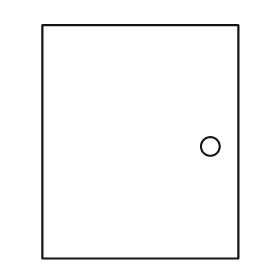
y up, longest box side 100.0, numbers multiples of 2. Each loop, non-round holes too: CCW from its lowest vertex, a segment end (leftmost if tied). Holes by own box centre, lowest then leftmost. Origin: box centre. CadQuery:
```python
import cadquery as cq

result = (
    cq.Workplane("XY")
    .moveTo(-42.0, -50.0)
    .lineTo(42.0, -50.0)
    .lineTo(42.0, 50.0)
    .lineTo(-42.0, 50.0)
    .close()
    .moveTo(30.0, -2.0)
    .circle(4.0)
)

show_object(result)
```